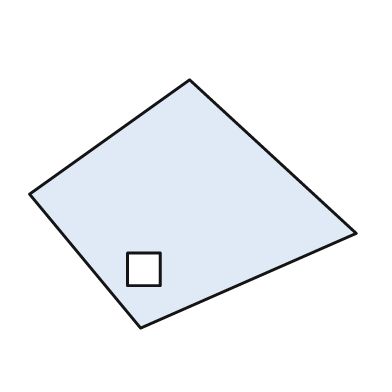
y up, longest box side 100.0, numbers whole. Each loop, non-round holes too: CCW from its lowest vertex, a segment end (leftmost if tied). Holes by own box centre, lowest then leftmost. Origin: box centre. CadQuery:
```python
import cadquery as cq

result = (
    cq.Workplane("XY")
    .moveTo(-16.0, -38.0)
    .lineTo(50.0, -9.0)
    .lineTo(-1.0, 38.0)
    .lineTo(-50.0, 3.0)
    .close()
    .moveTo(-20.0, -25.0)
    .lineTo(-10.0, -25.0)
    .lineTo(-10.0, -15.0)
    .lineTo(-20.0, -15.0)
    .close()
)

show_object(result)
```